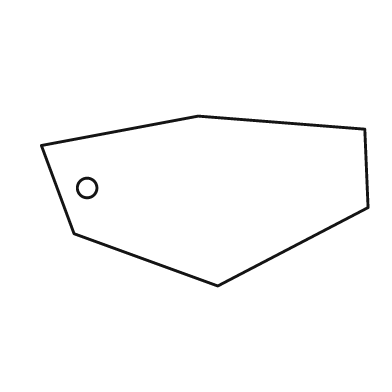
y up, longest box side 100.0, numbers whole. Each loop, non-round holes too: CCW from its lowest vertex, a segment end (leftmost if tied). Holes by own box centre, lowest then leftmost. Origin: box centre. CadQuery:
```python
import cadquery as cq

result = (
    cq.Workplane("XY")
    .moveTo(4.0, -26.0)
    .lineTo(50.0, -2.0)
    .lineTo(49.0, 22.0)
    .lineTo(-2.0, 26.0)
    .lineTo(-50.0, 17.0)
    .lineTo(-40.0, -10.0)
    .close()
    .moveTo(-36.0, 4.0)
    .circle(3.0)
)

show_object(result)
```